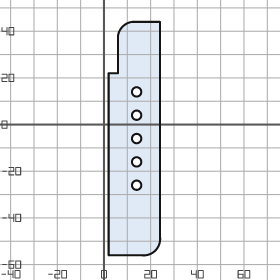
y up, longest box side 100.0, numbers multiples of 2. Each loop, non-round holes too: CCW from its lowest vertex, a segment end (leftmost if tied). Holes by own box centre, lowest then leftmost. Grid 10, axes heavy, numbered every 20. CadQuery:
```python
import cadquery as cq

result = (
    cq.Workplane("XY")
    .moveTo(2.0, -56.0)
    .lineTo(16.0, -56.0)
    .threePointArc((22.0, -54.0), (24.0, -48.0))
    .lineTo(24.0, 44.0)
    .lineTo(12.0, 44.0)
    .threePointArc((8.0, 42.0), (6.0, 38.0))
    .lineTo(6.0, 22.0)
    .lineTo(2.0, 22.0)
    .close()
    .moveTo(14.0, -26.0)
    .circle(2.0)
    .moveTo(14.0, -16.0)
    .circle(2.0)
    .moveTo(14.0, -6.0)
    .circle(2.0)
    .moveTo(14.0, 4.0)
    .circle(2.0)
    .moveTo(14.0, 14.0)
    .circle(2.0)
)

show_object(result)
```